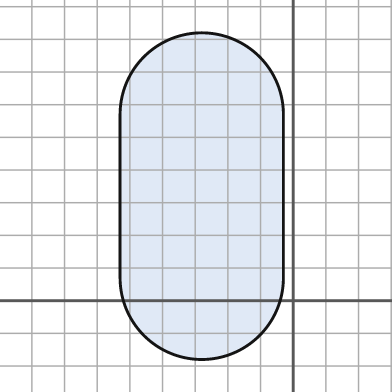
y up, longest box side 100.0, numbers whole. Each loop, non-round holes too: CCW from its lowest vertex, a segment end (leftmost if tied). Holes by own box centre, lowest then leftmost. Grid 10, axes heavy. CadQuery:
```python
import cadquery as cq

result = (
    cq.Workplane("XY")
    .moveTo(-53.0, 7.0)
    .threePointArc((-28.0, -18.0), (-3.0, 7.0))
    .lineTo(-3.0, 57.0)
    .threePointArc((-28.0, 82.0), (-53.0, 57.0))
    .close()
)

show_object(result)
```